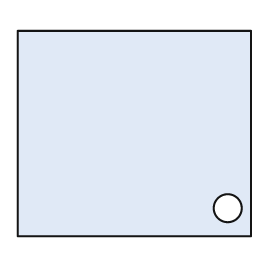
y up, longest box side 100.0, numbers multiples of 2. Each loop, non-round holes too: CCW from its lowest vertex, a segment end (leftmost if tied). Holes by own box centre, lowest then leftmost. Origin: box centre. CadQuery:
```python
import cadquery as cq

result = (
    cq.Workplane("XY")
    .moveTo(-50.0, -44.0)
    .lineTo(50.0, -44.0)
    .lineTo(50.0, 44.0)
    .lineTo(-50.0, 44.0)
    .close()
    .moveTo(40.0, -32.0)
    .circle(6.0)
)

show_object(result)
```